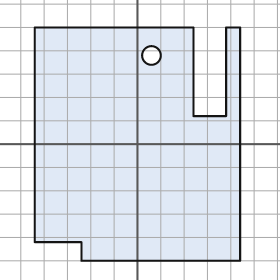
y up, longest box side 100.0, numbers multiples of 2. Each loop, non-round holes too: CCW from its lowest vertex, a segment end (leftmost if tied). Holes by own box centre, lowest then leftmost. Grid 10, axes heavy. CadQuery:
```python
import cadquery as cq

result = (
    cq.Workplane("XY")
    .moveTo(-24.0, -50.0)
    .lineTo(44.0, -50.0)
    .lineTo(44.0, 50.0)
    .lineTo(38.0, 50.0)
    .lineTo(38.0, 12.0)
    .lineTo(24.0, 12.0)
    .lineTo(24.0, 50.0)
    .lineTo(-44.0, 50.0)
    .lineTo(-44.0, -42.0)
    .lineTo(-24.0, -42.0)
    .close()
    .moveTo(6.0, 38.0)
    .circle(4.0)
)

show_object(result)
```